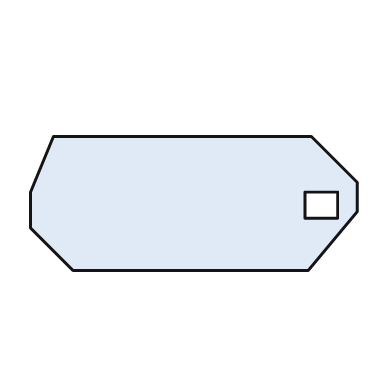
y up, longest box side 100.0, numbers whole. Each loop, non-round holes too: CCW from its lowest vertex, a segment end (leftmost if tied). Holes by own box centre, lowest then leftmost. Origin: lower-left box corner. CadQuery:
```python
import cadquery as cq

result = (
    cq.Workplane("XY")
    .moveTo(13.0, 0.0)
    .lineTo(85.0, 0.0)
    .lineTo(100.0, 18.0)
    .lineTo(100.0, 27.0)
    .lineTo(86.0, 41.0)
    .lineTo(7.0, 41.0)
    .lineTo(0.0, 24.0)
    .lineTo(0.0, 13.0)
    .close()
    .moveTo(84.0, 16.0)
    .lineTo(94.0, 16.0)
    .lineTo(94.0, 24.0)
    .lineTo(84.0, 24.0)
    .close()
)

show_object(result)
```